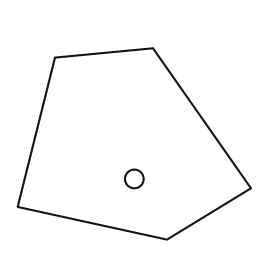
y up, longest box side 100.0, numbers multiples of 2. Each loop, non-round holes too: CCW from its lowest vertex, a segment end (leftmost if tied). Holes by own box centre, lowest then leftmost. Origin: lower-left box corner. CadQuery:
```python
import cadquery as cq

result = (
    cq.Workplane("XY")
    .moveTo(64.0, 0.0)
    .lineTo(100.0, 22.0)
    .lineTo(58.0, 82.0)
    .lineTo(16.0, 78.0)
    .lineTo(0.0, 14.0)
    .close()
    .moveTo(50.0, 26.0)
    .circle(4.0)
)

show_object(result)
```